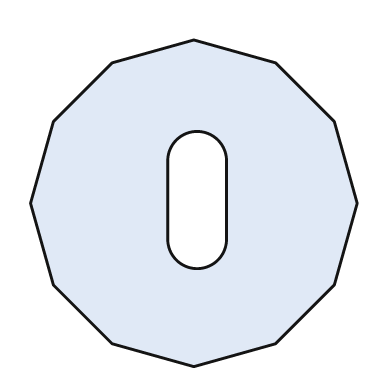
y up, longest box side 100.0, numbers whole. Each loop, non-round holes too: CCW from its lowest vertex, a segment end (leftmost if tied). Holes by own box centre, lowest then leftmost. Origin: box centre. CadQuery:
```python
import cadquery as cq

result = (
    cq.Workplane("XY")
    .moveTo(0.0, -50.0)
    .lineTo(25.0, -43.0)
    .lineTo(43.0, -25.0)
    .lineTo(50.0, 0.0)
    .lineTo(43.0, 25.0)
    .lineTo(25.0, 43.0)
    .lineTo(0.0, 50.0)
    .lineTo(-25.0, 43.0)
    .lineTo(-43.0, 25.0)
    .lineTo(-50.0, 0.0)
    .lineTo(-43.0, -25.0)
    .lineTo(-25.0, -43.0)
    .close()
    .moveTo(-8.0, -11.0)
    .threePointArc((1.0, -20.0), (10.0, -11.0))
    .lineTo(10.0, 13.0)
    .threePointArc((1.0, 22.0), (-8.0, 13.0))
    .close()
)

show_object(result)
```